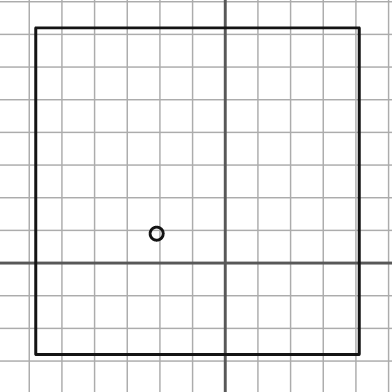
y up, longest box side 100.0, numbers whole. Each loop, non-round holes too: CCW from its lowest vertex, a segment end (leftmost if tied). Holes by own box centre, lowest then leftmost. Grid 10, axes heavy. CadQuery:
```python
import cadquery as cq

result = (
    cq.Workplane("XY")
    .moveTo(-58.0, -28.0)
    .lineTo(41.0, -28.0)
    .lineTo(41.0, 72.0)
    .lineTo(-58.0, 72.0)
    .close()
    .moveTo(-21.0, 9.0)
    .circle(2.0)
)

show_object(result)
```